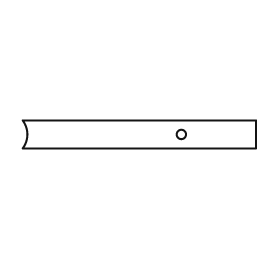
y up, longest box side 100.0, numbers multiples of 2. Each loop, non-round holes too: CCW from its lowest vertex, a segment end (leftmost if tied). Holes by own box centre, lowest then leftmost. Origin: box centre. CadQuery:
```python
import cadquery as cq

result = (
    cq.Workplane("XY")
    .moveTo(-50.0, -6.0)
    .lineTo(50.0, -6.0)
    .lineTo(50.0, 6.0)
    .lineTo(-50.0, 6.0)
    .threePointArc((-48.0, 0.0), (-50.0, -6.0))
    .close()
    .moveTo(18.0, 0.0)
    .circle(2.0)
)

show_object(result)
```